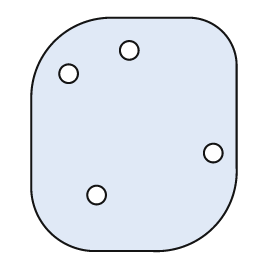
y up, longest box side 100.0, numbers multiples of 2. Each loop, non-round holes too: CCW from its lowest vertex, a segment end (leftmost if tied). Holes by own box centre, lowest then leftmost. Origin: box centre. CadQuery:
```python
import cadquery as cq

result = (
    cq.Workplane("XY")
    .moveTo(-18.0, -50.0)
    .lineTo(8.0, -50.0)
    .threePointArc((34.0, -40.0), (44.0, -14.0))
    .lineTo(44.0, 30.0)
    .threePointArc((38.0, 44.0), (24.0, 50.0))
    .lineTo(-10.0, 50.0)
    .threePointArc((-34.0, 40.0), (-44.0, 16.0))
    .lineTo(-44.0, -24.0)
    .threePointArc((-36.0, -42.0), (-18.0, -50.0))
    .close()
    .moveTo(-16.0, -26.0)
    .circle(4.0)
    .moveTo(34.0, -8.0)
    .circle(4.0)
    .moveTo(-28.0, 26.0)
    .circle(4.0)
    .moveTo(-2.0, 36.0)
    .circle(4.0)
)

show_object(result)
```